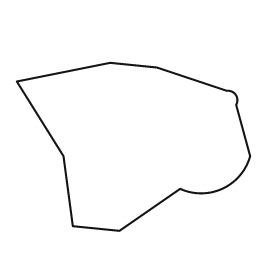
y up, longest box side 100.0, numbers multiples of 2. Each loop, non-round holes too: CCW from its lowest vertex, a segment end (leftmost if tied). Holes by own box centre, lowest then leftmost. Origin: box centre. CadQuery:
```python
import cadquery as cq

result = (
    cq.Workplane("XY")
    .moveTo(-6.0, -36.0)
    .lineTo(20.0, -18.0)
    .threePointArc((38.0, -18.0), (50.0, -4.0))
    .lineTo(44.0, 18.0)
    .threePointArc((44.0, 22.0), (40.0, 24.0))
    .lineTo(10.0, 34.0)
    .lineTo(-10.0, 36.0)
    .lineTo(-50.0, 28.0)
    .lineTo(-30.0, -4.0)
    .lineTo(-26.0, -34.0)
    .close()
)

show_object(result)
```